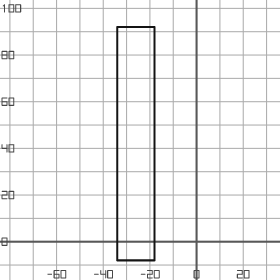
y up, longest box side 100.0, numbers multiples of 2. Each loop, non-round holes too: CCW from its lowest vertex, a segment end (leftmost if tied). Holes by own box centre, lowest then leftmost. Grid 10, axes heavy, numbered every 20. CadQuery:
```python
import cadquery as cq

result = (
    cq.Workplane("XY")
    .moveTo(-34.0, -8.0)
    .lineTo(-18.0, -8.0)
    .lineTo(-18.0, 92.0)
    .lineTo(-34.0, 92.0)
    .close()
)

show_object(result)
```